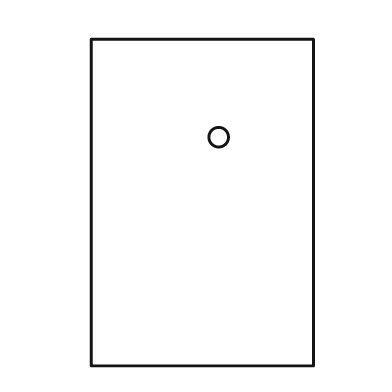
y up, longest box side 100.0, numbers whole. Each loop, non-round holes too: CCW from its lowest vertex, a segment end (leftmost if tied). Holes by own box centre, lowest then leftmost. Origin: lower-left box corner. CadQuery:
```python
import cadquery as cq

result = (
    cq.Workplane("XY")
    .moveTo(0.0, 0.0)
    .lineTo(68.0, 0.0)
    .lineTo(68.0, 100.0)
    .lineTo(0.0, 100.0)
    .close()
    .moveTo(39.0, 70.0)
    .circle(3.0)
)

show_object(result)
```